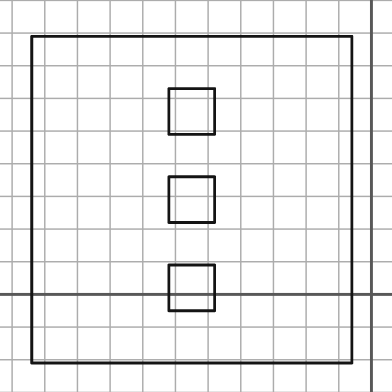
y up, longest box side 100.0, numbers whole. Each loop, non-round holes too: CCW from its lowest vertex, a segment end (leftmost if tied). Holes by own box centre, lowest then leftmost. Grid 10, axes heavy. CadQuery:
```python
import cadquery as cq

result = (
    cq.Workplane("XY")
    .moveTo(-104.0, -21.0)
    .lineTo(-6.0, -21.0)
    .lineTo(-6.0, 79.0)
    .lineTo(-104.0, 79.0)
    .close()
    .moveTo(-62.0, -5.0)
    .lineTo(-48.0, -5.0)
    .lineTo(-48.0, 9.0)
    .lineTo(-62.0, 9.0)
    .close()
    .moveTo(-62.0, 22.0)
    .lineTo(-48.0, 22.0)
    .lineTo(-48.0, 36.0)
    .lineTo(-62.0, 36.0)
    .close()
    .moveTo(-62.0, 49.0)
    .lineTo(-48.0, 49.0)
    .lineTo(-48.0, 63.0)
    .lineTo(-62.0, 63.0)
    .close()
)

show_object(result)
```